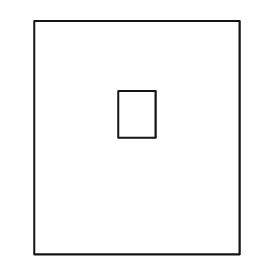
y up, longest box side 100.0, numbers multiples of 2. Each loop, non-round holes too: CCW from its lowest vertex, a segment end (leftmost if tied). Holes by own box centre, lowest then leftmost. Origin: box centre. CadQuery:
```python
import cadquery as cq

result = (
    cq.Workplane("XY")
    .moveTo(-44.0, -50.0)
    .lineTo(44.0, -50.0)
    .lineTo(44.0, 50.0)
    .lineTo(-44.0, 50.0)
    .close()
    .moveTo(-8.0, 0.0)
    .lineTo(8.0, 0.0)
    .lineTo(8.0, 20.0)
    .lineTo(-8.0, 20.0)
    .close()
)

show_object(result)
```